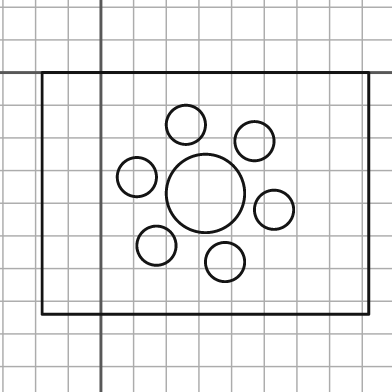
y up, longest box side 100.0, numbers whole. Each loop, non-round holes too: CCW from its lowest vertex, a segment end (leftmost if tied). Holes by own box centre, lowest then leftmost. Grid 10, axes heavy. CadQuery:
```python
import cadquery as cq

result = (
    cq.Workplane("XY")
    .moveTo(-18.0, -74.0)
    .lineTo(82.0, -74.0)
    .lineTo(82.0, 0.0)
    .lineTo(-18.0, 0.0)
    .close()
    .moveTo(38.0, -58.0)
    .circle(6.0)
    .moveTo(17.0, -53.0)
    .circle(6.0)
    .moveTo(53.0, -42.0)
    .circle(6.0)
    .moveTo(32.0, -37.0)
    .circle(12.0)
    .moveTo(11.0, -32.0)
    .circle(6.0)
    .moveTo(47.0, -21.0)
    .circle(6.0)
    .moveTo(26.0, -16.0)
    .circle(6.0)
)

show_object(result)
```